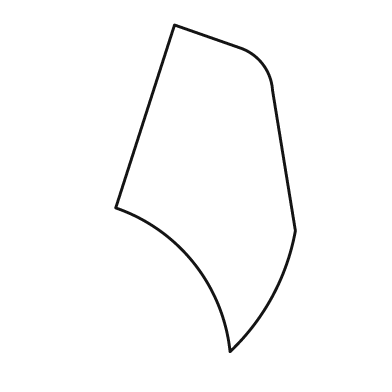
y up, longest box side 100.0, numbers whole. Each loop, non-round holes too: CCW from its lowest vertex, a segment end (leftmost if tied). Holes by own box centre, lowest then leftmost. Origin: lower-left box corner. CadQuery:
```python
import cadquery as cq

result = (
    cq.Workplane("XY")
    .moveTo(35.0, 0.0)
    .threePointArc((48.0, 17.0), (55.0, 37.0))
    .lineTo(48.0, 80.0)
    .threePointArc((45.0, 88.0), (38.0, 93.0))
    .lineTo(18.0, 100.0)
    .lineTo(0.0, 44.0)
    .threePointArc((24.0, 27.0), (35.0, 0.0))
    .close()
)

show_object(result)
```